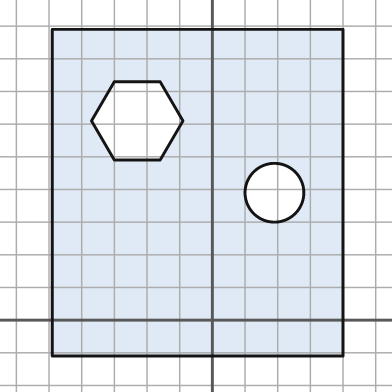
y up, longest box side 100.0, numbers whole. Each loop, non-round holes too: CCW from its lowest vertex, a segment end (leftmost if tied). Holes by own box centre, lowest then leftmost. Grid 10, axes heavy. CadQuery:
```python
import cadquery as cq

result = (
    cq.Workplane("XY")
    .moveTo(-49.0, -11.0)
    .lineTo(40.0, -11.0)
    .lineTo(40.0, 89.0)
    .lineTo(-49.0, 89.0)
    .close()
    .moveTo(19.0, 39.0)
    .circle(9.0)
    .moveTo(-30.0, 49.0)
    .lineTo(-16.0, 49.0)
    .lineTo(-9.0, 61.0)
    .lineTo(-16.0, 73.0)
    .lineTo(-30.0, 73.0)
    .lineTo(-37.0, 61.0)
    .close()
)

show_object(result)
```